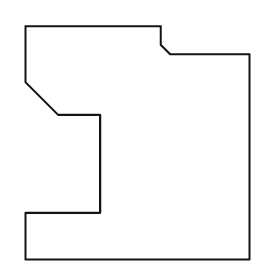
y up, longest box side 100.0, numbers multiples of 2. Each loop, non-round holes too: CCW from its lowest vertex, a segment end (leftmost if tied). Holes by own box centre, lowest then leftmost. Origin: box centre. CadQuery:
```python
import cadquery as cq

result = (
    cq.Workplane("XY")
    .moveTo(-48.0, -50.0)
    .lineTo(48.0, -50.0)
    .lineTo(48.0, 38.0)
    .lineTo(14.0, 38.0)
    .lineTo(10.0, 42.0)
    .lineTo(10.0, 50.0)
    .lineTo(-48.0, 50.0)
    .lineTo(-48.0, 26.0)
    .lineTo(-34.0, 12.0)
    .lineTo(-16.0, 12.0)
    .lineTo(-16.0, -30.0)
    .lineTo(-48.0, -30.0)
    .close()
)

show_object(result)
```